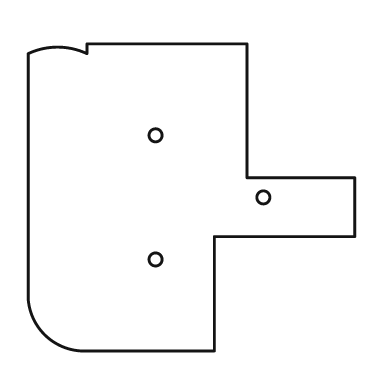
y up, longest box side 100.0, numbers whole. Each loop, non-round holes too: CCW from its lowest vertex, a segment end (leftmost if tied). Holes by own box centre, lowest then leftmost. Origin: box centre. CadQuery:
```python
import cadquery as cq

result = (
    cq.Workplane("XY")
    .moveTo(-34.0, -47.0)
    .lineTo(7.0, -47.0)
    .lineTo(7.0, -12.0)
    .lineTo(50.0, -12.0)
    .lineTo(50.0, 6.0)
    .lineTo(17.0, 6.0)
    .lineTo(17.0, 47.0)
    .lineTo(-32.0, 47.0)
    .lineTo(-32.0, 44.0)
    .threePointArc((-41.0, 46.0), (-50.0, 44.0))
    .lineTo(-50.0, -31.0)
    .threePointArc((-45.0, -42.0), (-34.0, -47.0))
    .close()
    .moveTo(-11.0, -19.0)
    .circle(2.0)
    .moveTo(22.0, 0.0)
    .circle(2.0)
    .moveTo(-11.0, 19.0)
    .circle(2.0)
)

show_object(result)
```